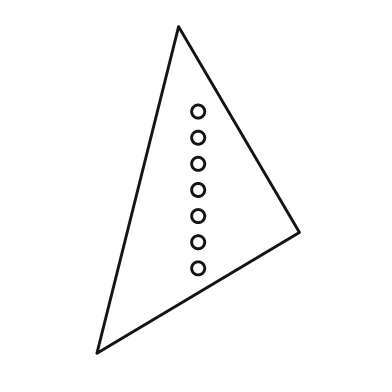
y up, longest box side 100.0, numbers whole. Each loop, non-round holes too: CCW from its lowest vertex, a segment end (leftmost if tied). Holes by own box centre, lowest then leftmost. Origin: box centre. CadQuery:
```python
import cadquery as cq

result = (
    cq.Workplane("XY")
    .moveTo(-31.0, -50.0)
    .lineTo(31.0, -13.0)
    .lineTo(-6.0, 50.0)
    .close()
    .moveTo(0.0, -24.0)
    .circle(2.0)
    .moveTo(0.0, -16.0)
    .circle(2.0)
    .moveTo(0.0, -8.0)
    .circle(2.0)
    .moveTo(0.0, 0.0)
    .circle(2.0)
    .moveTo(0.0, 8.0)
    .circle(2.0)
    .moveTo(0.0, 16.0)
    .circle(2.0)
    .moveTo(0.0, 24.0)
    .circle(2.0)
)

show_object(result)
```